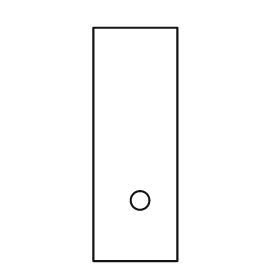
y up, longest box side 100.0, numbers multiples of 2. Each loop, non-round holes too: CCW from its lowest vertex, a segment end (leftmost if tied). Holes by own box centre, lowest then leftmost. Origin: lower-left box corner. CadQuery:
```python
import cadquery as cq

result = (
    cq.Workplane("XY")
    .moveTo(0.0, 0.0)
    .lineTo(36.0, 0.0)
    .lineTo(36.0, 100.0)
    .lineTo(0.0, 100.0)
    .close()
    .moveTo(20.0, 26.0)
    .circle(4.0)
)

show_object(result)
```